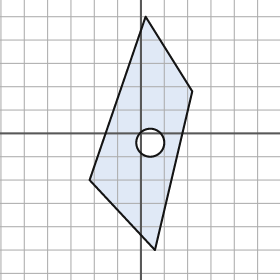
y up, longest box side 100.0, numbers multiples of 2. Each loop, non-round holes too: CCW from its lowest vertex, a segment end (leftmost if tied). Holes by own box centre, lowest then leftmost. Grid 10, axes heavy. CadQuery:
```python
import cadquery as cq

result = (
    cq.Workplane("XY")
    .moveTo(6.0, -50.0)
    .lineTo(22.0, 18.0)
    .lineTo(2.0, 50.0)
    .lineTo(-22.0, -20.0)
    .close()
    .moveTo(4.0, -4.0)
    .circle(6.0)
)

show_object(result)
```